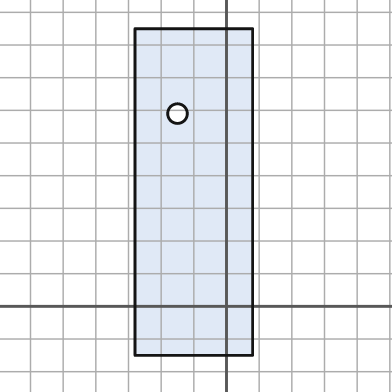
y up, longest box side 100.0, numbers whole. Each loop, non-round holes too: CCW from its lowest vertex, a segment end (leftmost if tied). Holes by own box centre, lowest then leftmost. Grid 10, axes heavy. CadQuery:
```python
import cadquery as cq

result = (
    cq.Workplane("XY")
    .moveTo(-28.0, -15.0)
    .lineTo(8.0, -15.0)
    .lineTo(8.0, 85.0)
    .lineTo(-28.0, 85.0)
    .close()
    .moveTo(-15.0, 59.0)
    .circle(3.0)
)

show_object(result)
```